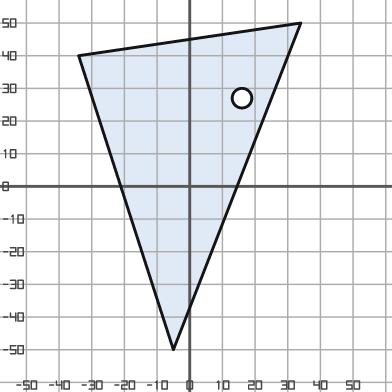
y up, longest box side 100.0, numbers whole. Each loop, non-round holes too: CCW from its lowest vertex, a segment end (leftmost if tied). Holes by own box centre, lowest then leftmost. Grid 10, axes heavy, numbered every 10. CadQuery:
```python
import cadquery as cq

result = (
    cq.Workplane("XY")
    .moveTo(-5.0, -50.0)
    .lineTo(34.0, 50.0)
    .lineTo(-34.0, 40.0)
    .close()
    .moveTo(16.0, 27.0)
    .circle(3.0)
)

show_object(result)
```